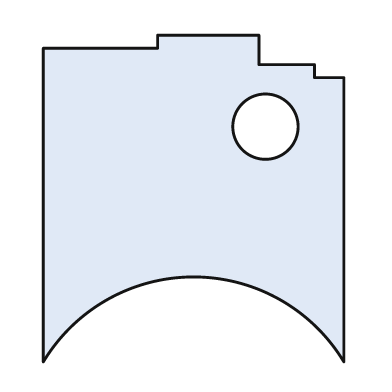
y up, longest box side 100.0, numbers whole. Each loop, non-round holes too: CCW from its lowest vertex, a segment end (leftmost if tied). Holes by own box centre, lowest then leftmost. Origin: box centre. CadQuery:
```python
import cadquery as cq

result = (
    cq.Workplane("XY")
    .moveTo(-46.0, -50.0)
    .threePointArc((0.0, -24.0), (46.0, -50.0))
    .lineTo(46.0, 37.0)
    .lineTo(37.0, 37.0)
    .lineTo(37.0, 41.0)
    .lineTo(20.0, 41.0)
    .lineTo(20.0, 50.0)
    .lineTo(-11.0, 50.0)
    .lineTo(-11.0, 46.0)
    .lineTo(-46.0, 46.0)
    .close()
    .moveTo(22.0, 22.0)
    .circle(10.0)
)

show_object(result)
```